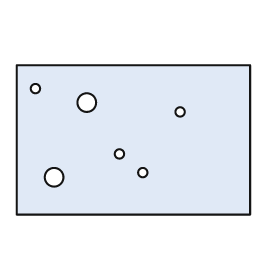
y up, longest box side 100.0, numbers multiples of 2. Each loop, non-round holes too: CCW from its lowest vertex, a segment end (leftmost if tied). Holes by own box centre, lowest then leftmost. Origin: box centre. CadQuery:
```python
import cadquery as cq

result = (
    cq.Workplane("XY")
    .moveTo(-50.0, -32.0)
    .lineTo(50.0, -32.0)
    .lineTo(50.0, 32.0)
    .lineTo(-50.0, 32.0)
    .close()
    .moveTo(-34.0, -16.0)
    .circle(4.0)
    .moveTo(4.0, -14.0)
    .circle(2.0)
    .moveTo(-6.0, -6.0)
    .circle(2.0)
    .moveTo(20.0, 12.0)
    .circle(2.0)
    .moveTo(-20.0, 16.0)
    .circle(4.0)
    .moveTo(-42.0, 22.0)
    .circle(2.0)
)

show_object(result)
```